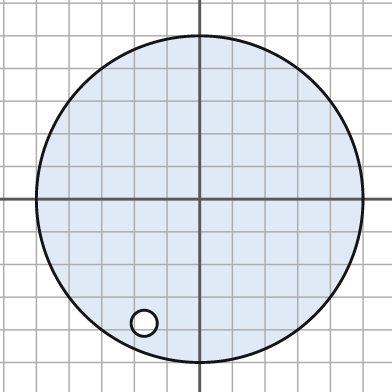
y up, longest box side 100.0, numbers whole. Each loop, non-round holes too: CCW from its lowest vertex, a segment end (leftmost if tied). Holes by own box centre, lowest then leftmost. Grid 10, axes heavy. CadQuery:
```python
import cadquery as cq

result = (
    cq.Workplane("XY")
    .moveTo(0.0, 0.0)
    .circle(50.0)
    .moveTo(-17.0, -38.0)
    .circle(4.0)
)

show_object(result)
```